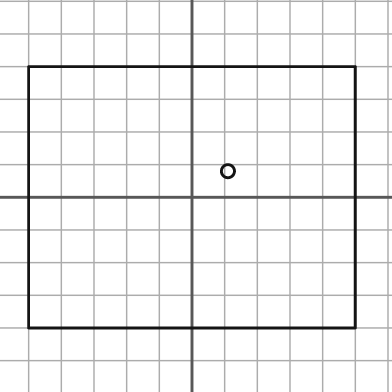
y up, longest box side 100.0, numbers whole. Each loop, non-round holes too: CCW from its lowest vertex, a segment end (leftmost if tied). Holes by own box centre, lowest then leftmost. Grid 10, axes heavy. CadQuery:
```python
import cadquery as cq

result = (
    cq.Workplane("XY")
    .moveTo(-50.0, -40.0)
    .lineTo(50.0, -40.0)
    .lineTo(50.0, 40.0)
    .lineTo(-50.0, 40.0)
    .close()
    .moveTo(11.0, 8.0)
    .circle(2.0)
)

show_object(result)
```